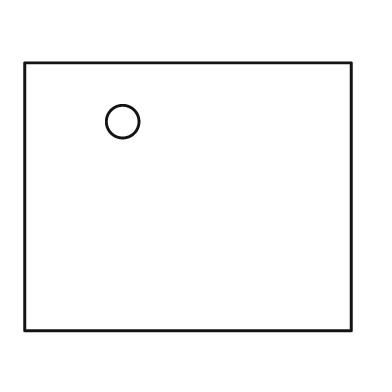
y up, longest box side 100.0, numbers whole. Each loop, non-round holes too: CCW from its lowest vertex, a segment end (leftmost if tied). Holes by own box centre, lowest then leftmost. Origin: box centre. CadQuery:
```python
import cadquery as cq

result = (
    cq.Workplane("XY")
    .moveTo(-50.0, -41.0)
    .lineTo(50.0, -41.0)
    .lineTo(50.0, 41.0)
    .lineTo(-50.0, 41.0)
    .close()
    .moveTo(-20.0, 23.0)
    .circle(5.0)
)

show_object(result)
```